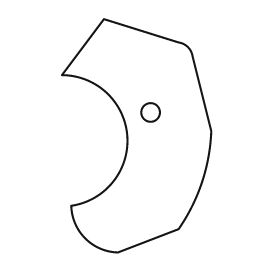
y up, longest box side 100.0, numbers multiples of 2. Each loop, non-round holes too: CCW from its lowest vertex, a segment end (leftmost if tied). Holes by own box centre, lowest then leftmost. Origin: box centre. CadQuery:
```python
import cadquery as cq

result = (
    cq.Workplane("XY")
    .moveTo(-8.0, -50.0)
    .lineTo(18.0, -40.0)
    .threePointArc((28.0, -20.0), (32.0, 2.0))
    .lineTo(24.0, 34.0)
    .threePointArc((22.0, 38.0), (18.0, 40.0))
    .lineTo(-14.0, 50.0)
    .lineTo(-32.0, 26.0)
    .threePointArc((-4.0, 0.0), (-28.0, -30.0))
    .threePointArc((-22.0, -44.0), (-8.0, -50.0))
    .close()
    .moveTo(6.0, 10.0)
    .circle(4.0)
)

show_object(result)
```